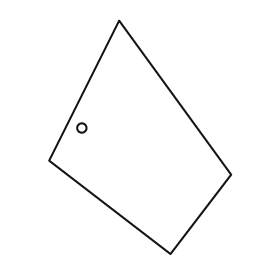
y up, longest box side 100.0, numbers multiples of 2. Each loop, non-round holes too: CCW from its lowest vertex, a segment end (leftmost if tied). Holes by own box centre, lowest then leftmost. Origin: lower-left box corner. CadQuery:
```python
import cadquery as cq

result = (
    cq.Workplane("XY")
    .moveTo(52.0, 0.0)
    .lineTo(78.0, 34.0)
    .lineTo(30.0, 100.0)
    .lineTo(0.0, 40.0)
    .close()
    .moveTo(14.0, 54.0)
    .circle(2.0)
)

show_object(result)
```